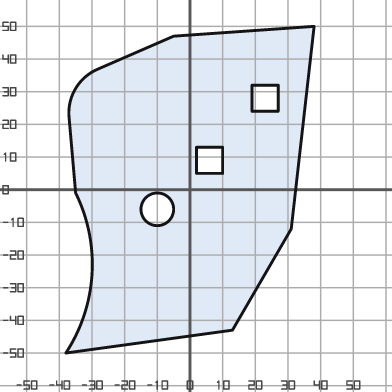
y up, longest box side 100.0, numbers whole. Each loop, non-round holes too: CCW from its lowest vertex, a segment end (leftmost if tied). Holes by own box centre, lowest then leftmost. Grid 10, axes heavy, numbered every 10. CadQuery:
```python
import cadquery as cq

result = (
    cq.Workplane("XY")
    .moveTo(-38.0, -50.0)
    .lineTo(13.0, -43.0)
    .lineTo(31.0, -12.0)
    .lineTo(38.0, 50.0)
    .lineTo(-5.0, 47.0)
    .lineTo(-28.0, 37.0)
    .threePointArc((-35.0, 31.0), (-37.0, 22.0))
    .lineTo(-35.0, -1.0)
    .threePointArc((-30.0, -26.0), (-38.0, -50.0))
    .close()
    .moveTo(-10.0, -6.0)
    .circle(5.0)
    .moveTo(2.0, 5.0)
    .lineTo(10.0, 5.0)
    .lineTo(10.0, 13.0)
    .lineTo(2.0, 13.0)
    .close()
    .moveTo(19.0, 24.0)
    .lineTo(27.0, 24.0)
    .lineTo(27.0, 32.0)
    .lineTo(19.0, 32.0)
    .close()
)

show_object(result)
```